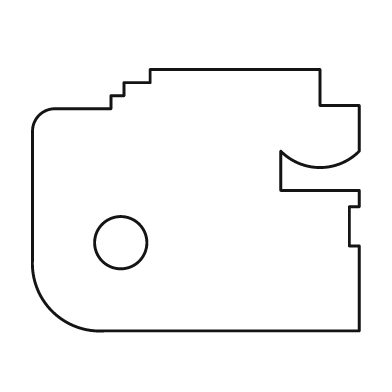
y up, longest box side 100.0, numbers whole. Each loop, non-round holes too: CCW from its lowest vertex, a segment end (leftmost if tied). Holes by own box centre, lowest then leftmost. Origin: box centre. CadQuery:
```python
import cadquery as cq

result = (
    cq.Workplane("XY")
    .moveTo(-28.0, -40.0)
    .lineTo(50.0, -40.0)
    .lineTo(50.0, -14.0)
    .lineTo(47.0, -14.0)
    .lineTo(47.0, -2.0)
    .lineTo(50.0, -2.0)
    .lineTo(50.0, 3.0)
    .lineTo(26.0, 3.0)
    .lineTo(26.0, 15.0)
    .threePointArc((38.0, 10.0), (50.0, 15.0))
    .lineTo(50.0, 29.0)
    .lineTo(38.0, 29.0)
    .lineTo(38.0, 40.0)
    .lineTo(-14.0, 40.0)
    .lineTo(-14.0, 36.0)
    .lineTo(-22.0, 36.0)
    .lineTo(-22.0, 32.0)
    .lineTo(-26.0, 32.0)
    .lineTo(-26.0, 28.0)
    .lineTo(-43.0, 28.0)
    .threePointArc((-48.0, 26.0), (-50.0, 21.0))
    .lineTo(-50.0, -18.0)
    .threePointArc((-44.0, -34.0), (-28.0, -40.0))
    .close()
    .moveTo(-23.0, -13.0)
    .circle(8.0)
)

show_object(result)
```